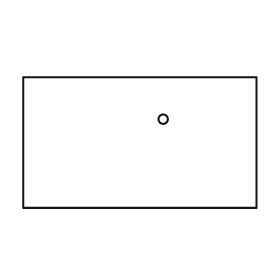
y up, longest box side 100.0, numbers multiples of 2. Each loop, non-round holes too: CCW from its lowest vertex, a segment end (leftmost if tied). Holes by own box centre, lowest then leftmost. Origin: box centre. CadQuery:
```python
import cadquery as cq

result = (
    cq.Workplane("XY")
    .moveTo(-50.0, -28.0)
    .lineTo(50.0, -28.0)
    .lineTo(50.0, 28.0)
    .lineTo(-50.0, 28.0)
    .close()
    .moveTo(10.0, 10.0)
    .circle(2.0)
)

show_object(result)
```